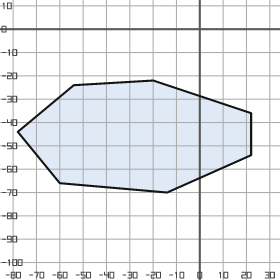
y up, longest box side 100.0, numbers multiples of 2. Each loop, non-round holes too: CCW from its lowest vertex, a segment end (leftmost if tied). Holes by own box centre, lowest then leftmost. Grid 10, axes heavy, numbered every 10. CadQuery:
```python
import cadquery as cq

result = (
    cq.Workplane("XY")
    .moveTo(-14.0, -70.0)
    .lineTo(22.0, -54.0)
    .lineTo(22.0, -36.0)
    .lineTo(-20.0, -22.0)
    .lineTo(-54.0, -24.0)
    .lineTo(-78.0, -44.0)
    .lineTo(-60.0, -66.0)
    .close()
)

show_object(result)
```